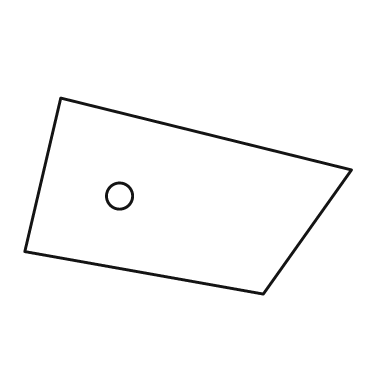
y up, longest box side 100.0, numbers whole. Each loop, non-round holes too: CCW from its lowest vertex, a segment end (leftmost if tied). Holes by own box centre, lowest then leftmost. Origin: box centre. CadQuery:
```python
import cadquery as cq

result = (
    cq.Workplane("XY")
    .moveTo(23.0, -30.0)
    .lineTo(50.0, 8.0)
    .lineTo(-39.0, 30.0)
    .lineTo(-50.0, -17.0)
    .close()
    .moveTo(-21.0, 0.0)
    .circle(4.0)
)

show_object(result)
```